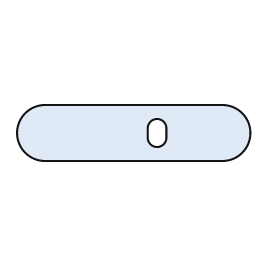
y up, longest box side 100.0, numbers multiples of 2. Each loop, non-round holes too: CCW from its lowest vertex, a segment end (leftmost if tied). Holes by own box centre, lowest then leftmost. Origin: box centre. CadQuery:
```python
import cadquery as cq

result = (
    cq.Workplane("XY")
    .moveTo(-38.0, -12.0)
    .lineTo(38.0, -12.0)
    .threePointArc((50.0, 0.0), (38.0, 12.0))
    .lineTo(-38.0, 12.0)
    .threePointArc((-50.0, 0.0), (-38.0, -12.0))
    .close()
    .moveTo(6.0, -2.0)
    .threePointArc((10.0, -6.0), (14.0, -2.0))
    .lineTo(14.0, 2.0)
    .threePointArc((10.0, 6.0), (6.0, 2.0))
    .close()
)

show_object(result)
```